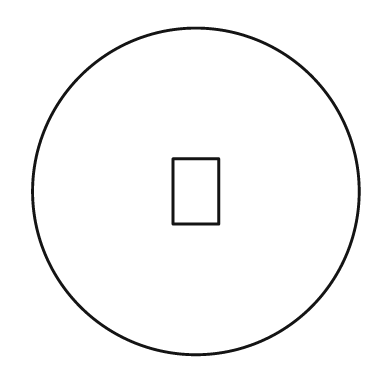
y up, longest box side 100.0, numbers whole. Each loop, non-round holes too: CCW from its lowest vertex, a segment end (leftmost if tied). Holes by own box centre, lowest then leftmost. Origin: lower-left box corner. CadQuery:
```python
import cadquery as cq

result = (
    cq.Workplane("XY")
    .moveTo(50.0, 50.0)
    .circle(50.0)
    .moveTo(43.0, 40.0)
    .lineTo(57.0, 40.0)
    .lineTo(57.0, 60.0)
    .lineTo(43.0, 60.0)
    .close()
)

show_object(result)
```